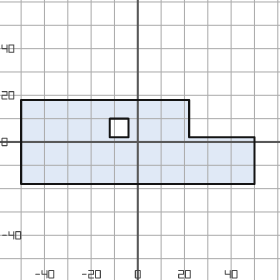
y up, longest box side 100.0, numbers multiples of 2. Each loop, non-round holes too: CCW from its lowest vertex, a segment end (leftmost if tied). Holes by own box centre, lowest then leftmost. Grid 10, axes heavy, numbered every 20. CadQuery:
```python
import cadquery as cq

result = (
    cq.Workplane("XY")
    .moveTo(-50.0, -18.0)
    .lineTo(50.0, -18.0)
    .lineTo(50.0, 2.0)
    .lineTo(22.0, 2.0)
    .lineTo(22.0, 18.0)
    .lineTo(-50.0, 18.0)
    .close()
    .moveTo(-12.0, 2.0)
    .lineTo(-4.0, 2.0)
    .lineTo(-4.0, 10.0)
    .lineTo(-12.0, 10.0)
    .close()
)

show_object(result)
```